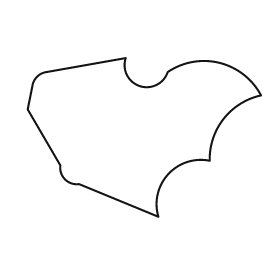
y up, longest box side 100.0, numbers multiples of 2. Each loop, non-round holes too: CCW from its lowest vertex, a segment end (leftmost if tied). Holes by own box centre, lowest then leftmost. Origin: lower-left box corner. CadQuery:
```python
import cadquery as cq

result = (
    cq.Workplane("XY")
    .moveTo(56.0, 0.0)
    .threePointArc((60.0, 18.0), (78.0, 24.0))
    .threePointArc((84.0, 42.0), (100.0, 52.0))
    .threePointArc((82.0, 66.0), (60.0, 62.0))
    .threePointArc((48.0, 56.0), (42.0, 68.0))
    .lineTo(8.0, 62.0)
    .threePointArc((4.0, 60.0), (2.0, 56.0))
    .lineTo(0.0, 46.0)
    .lineTo(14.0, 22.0)
    .threePointArc((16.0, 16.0), (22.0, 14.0))
    .close()
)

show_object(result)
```